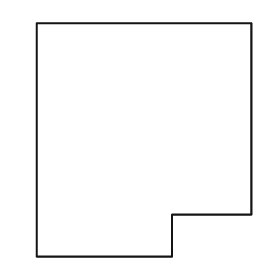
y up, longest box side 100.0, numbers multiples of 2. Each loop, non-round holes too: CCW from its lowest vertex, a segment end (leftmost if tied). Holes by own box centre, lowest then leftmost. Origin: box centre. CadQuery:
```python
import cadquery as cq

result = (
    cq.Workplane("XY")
    .moveTo(-46.0, -50.0)
    .lineTo(12.0, -50.0)
    .lineTo(12.0, -32.0)
    .lineTo(46.0, -32.0)
    .lineTo(46.0, 50.0)
    .lineTo(-46.0, 50.0)
    .close()
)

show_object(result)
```